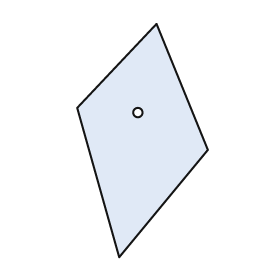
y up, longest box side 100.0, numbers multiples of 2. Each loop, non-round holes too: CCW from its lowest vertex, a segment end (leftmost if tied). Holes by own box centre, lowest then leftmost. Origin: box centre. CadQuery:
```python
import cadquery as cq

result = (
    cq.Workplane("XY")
    .moveTo(-10.0, -50.0)
    .lineTo(28.0, -4.0)
    .lineTo(6.0, 50.0)
    .lineTo(-28.0, 14.0)
    .close()
    .moveTo(-2.0, 12.0)
    .circle(2.0)
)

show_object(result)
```